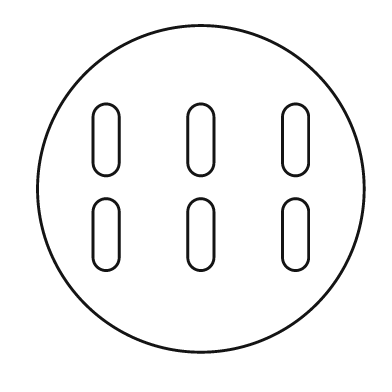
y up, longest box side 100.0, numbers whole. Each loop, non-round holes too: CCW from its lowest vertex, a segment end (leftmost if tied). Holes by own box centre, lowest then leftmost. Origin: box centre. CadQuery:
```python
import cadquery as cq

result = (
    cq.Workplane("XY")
    .moveTo(0.0, 0.0)
    .circle(50.0)
    .moveTo(-33.0, -21.0)
    .threePointArc((-29.0, -25.0), (-25.0, -21.0))
    .lineTo(-25.0, -7.0)
    .threePointArc((-29.0, -3.0), (-33.0, -7.0))
    .close()
    .moveTo(-4.0, -21.0)
    .threePointArc((0.0, -25.0), (4.0, -21.0))
    .lineTo(4.0, -7.0)
    .threePointArc((0.0, -3.0), (-4.0, -7.0))
    .close()
    .moveTo(25.0, -21.0)
    .threePointArc((29.0, -25.0), (33.0, -21.0))
    .lineTo(33.0, -7.0)
    .threePointArc((29.0, -3.0), (25.0, -7.0))
    .close()
    .moveTo(-33.0, 8.0)
    .threePointArc((-29.0, 4.0), (-25.0, 8.0))
    .lineTo(-25.0, 22.0)
    .threePointArc((-29.0, 26.0), (-33.0, 22.0))
    .close()
    .moveTo(-4.0, 8.0)
    .threePointArc((0.0, 4.0), (4.0, 8.0))
    .lineTo(4.0, 22.0)
    .threePointArc((0.0, 26.0), (-4.0, 22.0))
    .close()
    .moveTo(25.0, 8.0)
    .threePointArc((29.0, 4.0), (33.0, 8.0))
    .lineTo(33.0, 22.0)
    .threePointArc((29.0, 26.0), (25.0, 22.0))
    .close()
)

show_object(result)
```